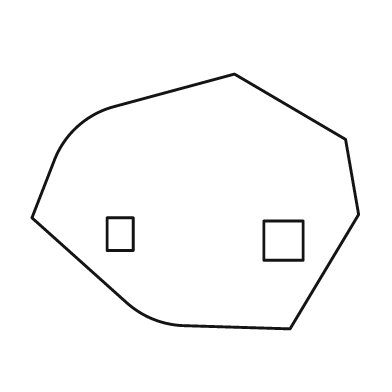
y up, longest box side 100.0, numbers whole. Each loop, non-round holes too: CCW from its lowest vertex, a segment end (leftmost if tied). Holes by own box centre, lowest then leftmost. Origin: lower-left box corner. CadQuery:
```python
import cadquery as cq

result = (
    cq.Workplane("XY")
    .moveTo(79.0, 0.0)
    .lineTo(100.0, 35.0)
    .lineTo(96.0, 58.0)
    .lineTo(62.0, 78.0)
    .lineTo(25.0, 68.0)
    .threePointArc((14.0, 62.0), (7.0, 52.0))
    .lineTo(0.0, 34.0)
    .lineTo(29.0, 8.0)
    .threePointArc((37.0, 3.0), (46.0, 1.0))
    .close()
    .moveTo(71.0, 21.0)
    .lineTo(83.0, 21.0)
    .lineTo(83.0, 33.0)
    .lineTo(71.0, 33.0)
    .close()
    .moveTo(23.0, 24.0)
    .lineTo(31.0, 24.0)
    .lineTo(31.0, 34.0)
    .lineTo(23.0, 34.0)
    .close()
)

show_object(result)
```